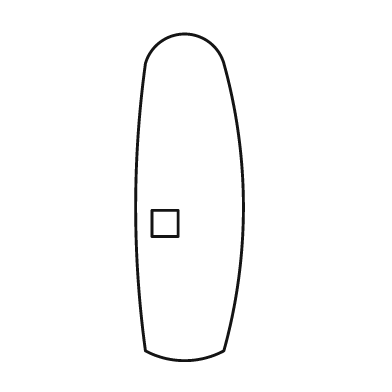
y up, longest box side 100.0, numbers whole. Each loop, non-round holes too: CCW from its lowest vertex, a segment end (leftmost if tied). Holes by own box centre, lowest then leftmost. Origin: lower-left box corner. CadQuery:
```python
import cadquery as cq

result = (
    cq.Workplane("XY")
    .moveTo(3.0, 3.0)
    .threePointArc((15.0, 0.0), (27.0, 3.0))
    .threePointArc((33.0, 47.0), (27.0, 91.0))
    .threePointArc((15.0, 100.0), (3.0, 91.0))
    .threePointArc((0.0, 47.0), (3.0, 3.0))
    .close()
    .moveTo(5.0, 38.0)
    .lineTo(13.0, 38.0)
    .lineTo(13.0, 46.0)
    .lineTo(5.0, 46.0)
    .close()
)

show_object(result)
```